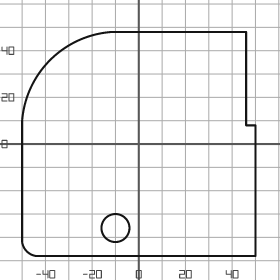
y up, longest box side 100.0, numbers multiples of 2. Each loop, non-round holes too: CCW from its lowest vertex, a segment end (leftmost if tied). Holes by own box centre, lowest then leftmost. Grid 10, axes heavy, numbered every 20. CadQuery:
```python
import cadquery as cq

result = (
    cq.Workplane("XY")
    .moveTo(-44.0, -48.0)
    .lineTo(50.0, -48.0)
    .lineTo(50.0, 8.0)
    .lineTo(46.0, 8.0)
    .lineTo(46.0, 48.0)
    .lineTo(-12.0, 48.0)
    .threePointArc((-38.0, 36.0), (-50.0, 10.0))
    .lineTo(-50.0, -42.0)
    .threePointArc((-48.0, -46.0), (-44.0, -48.0))
    .close()
    .moveTo(-10.0, -36.0)
    .circle(6.0)
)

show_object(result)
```